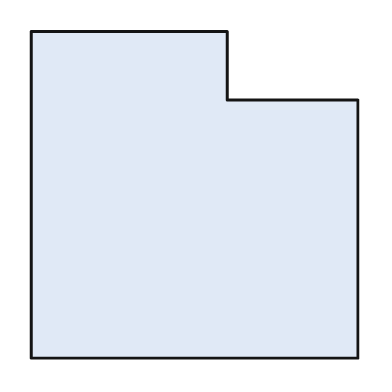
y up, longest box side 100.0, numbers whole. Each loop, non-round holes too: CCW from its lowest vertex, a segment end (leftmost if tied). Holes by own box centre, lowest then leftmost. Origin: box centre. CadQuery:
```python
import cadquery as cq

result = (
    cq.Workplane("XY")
    .moveTo(-50.0, -50.0)
    .lineTo(50.0, -50.0)
    .lineTo(50.0, 29.0)
    .lineTo(10.0, 29.0)
    .lineTo(10.0, 50.0)
    .lineTo(-50.0, 50.0)
    .close()
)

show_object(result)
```